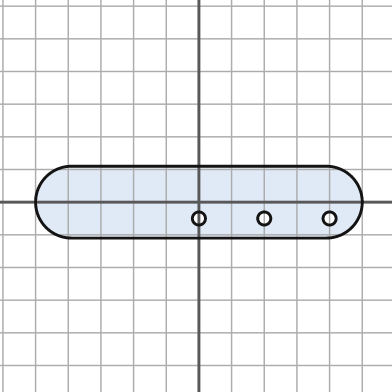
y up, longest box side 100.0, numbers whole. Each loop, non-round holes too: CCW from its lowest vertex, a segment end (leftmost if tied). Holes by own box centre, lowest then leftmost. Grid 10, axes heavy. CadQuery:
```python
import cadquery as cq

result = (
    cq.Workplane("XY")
    .moveTo(-39.0, -11.0)
    .lineTo(39.0, -11.0)
    .threePointArc((50.0, 0.0), (39.0, 11.0))
    .lineTo(-39.0, 11.0)
    .threePointArc((-50.0, 0.0), (-39.0, -11.0))
    .close()
    .moveTo(0.0, -5.0)
    .circle(2.0)
    .moveTo(20.0, -5.0)
    .circle(2.0)
    .moveTo(40.0, -5.0)
    .circle(2.0)
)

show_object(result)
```